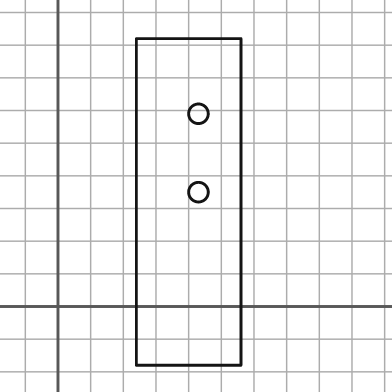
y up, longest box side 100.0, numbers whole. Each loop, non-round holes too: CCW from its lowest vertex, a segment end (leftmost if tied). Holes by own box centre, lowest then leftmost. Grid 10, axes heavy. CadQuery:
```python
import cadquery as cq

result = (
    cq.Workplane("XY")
    .moveTo(24.0, -18.0)
    .lineTo(56.0, -18.0)
    .lineTo(56.0, 82.0)
    .lineTo(24.0, 82.0)
    .close()
    .moveTo(43.0, 35.0)
    .circle(3.0)
    .moveTo(43.0, 59.0)
    .circle(3.0)
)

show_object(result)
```